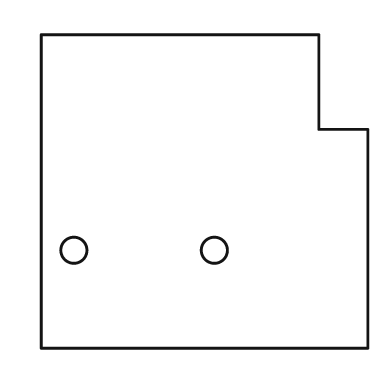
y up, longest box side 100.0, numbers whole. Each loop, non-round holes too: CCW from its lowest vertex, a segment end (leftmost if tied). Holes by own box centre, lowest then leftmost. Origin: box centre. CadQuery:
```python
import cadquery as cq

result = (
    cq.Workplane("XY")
    .moveTo(-50.0, -48.0)
    .lineTo(50.0, -48.0)
    .lineTo(50.0, 19.0)
    .lineTo(35.0, 19.0)
    .lineTo(35.0, 48.0)
    .lineTo(-50.0, 48.0)
    .close()
    .moveTo(-40.0, -18.0)
    .circle(4.0)
    .moveTo(3.0, -18.0)
    .circle(4.0)
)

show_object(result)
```